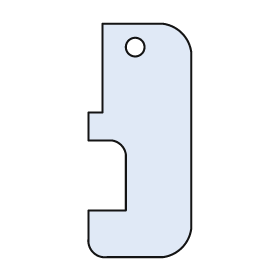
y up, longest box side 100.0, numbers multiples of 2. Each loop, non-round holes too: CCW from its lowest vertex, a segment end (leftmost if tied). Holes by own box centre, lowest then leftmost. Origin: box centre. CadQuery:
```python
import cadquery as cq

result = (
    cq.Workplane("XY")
    .moveTo(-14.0, -50.0)
    .lineTo(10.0, -50.0)
    .threePointArc((18.0, -46.0), (22.0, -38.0))
    .lineTo(22.0, 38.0)
    .threePointArc((18.0, 46.0), (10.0, 50.0))
    .lineTo(-16.0, 50.0)
    .lineTo(-16.0, 12.0)
    .lineTo(-22.0, 12.0)
    .lineTo(-22.0, 0.0)
    .lineTo(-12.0, 0.0)
    .threePointArc((-8.0, -2.0), (-6.0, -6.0))
    .lineTo(-6.0, -30.0)
    .lineTo(-22.0, -30.0)
    .lineTo(-22.0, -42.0)
    .threePointArc((-20.0, -48.0), (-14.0, -50.0))
    .close()
    .moveTo(-2.0, 40.0)
    .circle(4.0)
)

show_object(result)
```